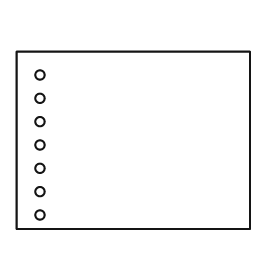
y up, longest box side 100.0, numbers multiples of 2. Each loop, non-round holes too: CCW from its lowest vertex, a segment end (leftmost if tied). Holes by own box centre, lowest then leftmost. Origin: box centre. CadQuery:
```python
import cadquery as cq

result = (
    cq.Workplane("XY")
    .moveTo(-50.0, -38.0)
    .lineTo(50.0, -38.0)
    .lineTo(50.0, 38.0)
    .lineTo(-50.0, 38.0)
    .close()
    .moveTo(-40.0, -32.0)
    .circle(2.0)
    .moveTo(-40.0, -22.0)
    .circle(2.0)
    .moveTo(-40.0, -12.0)
    .circle(2.0)
    .moveTo(-40.0, -2.0)
    .circle(2.0)
    .moveTo(-40.0, 8.0)
    .circle(2.0)
    .moveTo(-40.0, 18.0)
    .circle(2.0)
    .moveTo(-40.0, 28.0)
    .circle(2.0)
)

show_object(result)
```